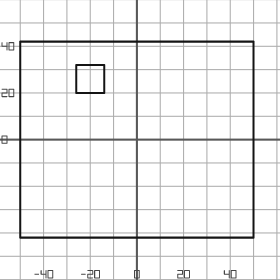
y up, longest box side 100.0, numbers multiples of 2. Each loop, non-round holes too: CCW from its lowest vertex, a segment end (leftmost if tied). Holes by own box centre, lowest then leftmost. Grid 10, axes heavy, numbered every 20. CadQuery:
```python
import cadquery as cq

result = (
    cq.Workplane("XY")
    .moveTo(-50.0, -42.0)
    .lineTo(50.0, -42.0)
    .lineTo(50.0, 42.0)
    .lineTo(-50.0, 42.0)
    .close()
    .moveTo(-26.0, 20.0)
    .lineTo(-14.0, 20.0)
    .lineTo(-14.0, 32.0)
    .lineTo(-26.0, 32.0)
    .close()
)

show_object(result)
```